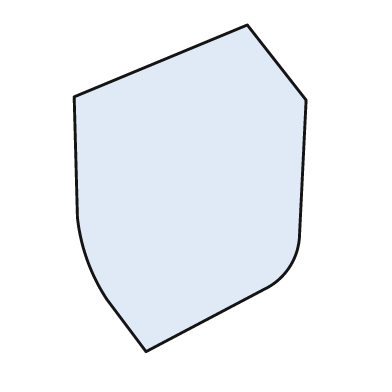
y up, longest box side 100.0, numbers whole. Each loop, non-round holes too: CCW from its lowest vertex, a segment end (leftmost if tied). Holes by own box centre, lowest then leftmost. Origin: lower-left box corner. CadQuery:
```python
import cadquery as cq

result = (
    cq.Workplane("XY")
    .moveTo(22.0, 0.0)
    .lineTo(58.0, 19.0)
    .threePointArc((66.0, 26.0), (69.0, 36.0))
    .lineTo(71.0, 77.0)
    .lineTo(53.0, 100.0)
    .lineTo(0.0, 78.0)
    .lineTo(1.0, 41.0)
    .threePointArc((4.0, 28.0), (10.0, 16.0))
    .close()
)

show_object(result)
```